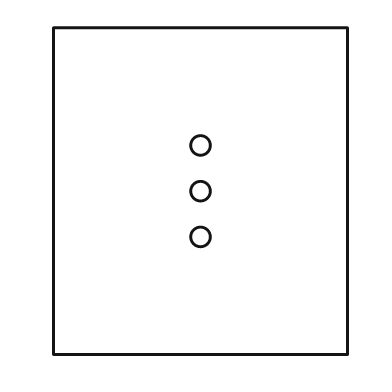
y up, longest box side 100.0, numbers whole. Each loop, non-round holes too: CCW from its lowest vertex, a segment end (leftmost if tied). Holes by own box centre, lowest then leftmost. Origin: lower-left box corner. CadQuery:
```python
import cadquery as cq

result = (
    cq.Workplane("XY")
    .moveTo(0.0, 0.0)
    .lineTo(90.0, 0.0)
    .lineTo(90.0, 100.0)
    .lineTo(0.0, 100.0)
    .close()
    .moveTo(45.0, 36.0)
    .circle(3.0)
    .moveTo(45.0, 50.0)
    .circle(3.0)
    .moveTo(45.0, 64.0)
    .circle(3.0)
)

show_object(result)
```